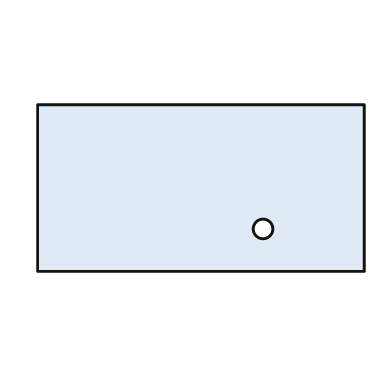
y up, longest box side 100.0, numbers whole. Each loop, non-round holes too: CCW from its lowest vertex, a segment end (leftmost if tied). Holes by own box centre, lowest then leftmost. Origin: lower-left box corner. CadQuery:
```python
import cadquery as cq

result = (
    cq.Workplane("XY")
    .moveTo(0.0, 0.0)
    .lineTo(100.0, 0.0)
    .lineTo(100.0, 51.0)
    .lineTo(0.0, 51.0)
    .close()
    .moveTo(69.0, 13.0)
    .circle(3.0)
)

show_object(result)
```